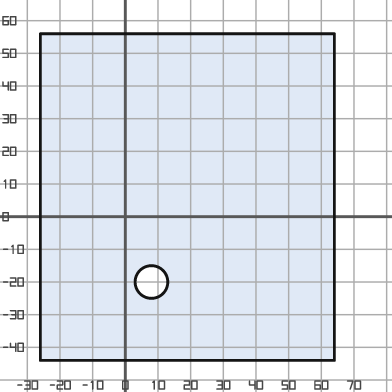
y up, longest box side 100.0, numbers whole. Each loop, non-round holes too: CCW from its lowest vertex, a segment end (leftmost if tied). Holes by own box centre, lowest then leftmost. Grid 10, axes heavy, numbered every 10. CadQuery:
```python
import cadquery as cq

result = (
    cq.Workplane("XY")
    .moveTo(-26.0, -44.0)
    .lineTo(64.0, -44.0)
    .lineTo(64.0, 56.0)
    .lineTo(-26.0, 56.0)
    .close()
    .moveTo(8.0, -20.0)
    .circle(5.0)
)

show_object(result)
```